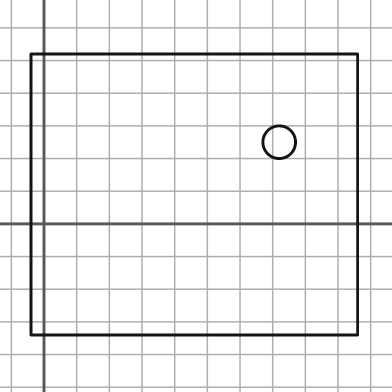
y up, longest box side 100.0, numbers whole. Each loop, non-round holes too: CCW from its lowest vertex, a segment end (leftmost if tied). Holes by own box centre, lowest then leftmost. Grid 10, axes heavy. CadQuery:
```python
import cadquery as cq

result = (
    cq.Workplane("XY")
    .moveTo(-4.0, -34.0)
    .lineTo(96.0, -34.0)
    .lineTo(96.0, 52.0)
    .lineTo(-4.0, 52.0)
    .close()
    .moveTo(72.0, 25.0)
    .circle(5.0)
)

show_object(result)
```